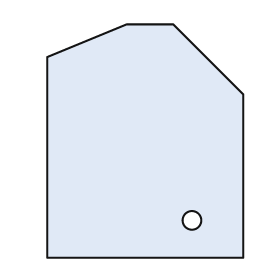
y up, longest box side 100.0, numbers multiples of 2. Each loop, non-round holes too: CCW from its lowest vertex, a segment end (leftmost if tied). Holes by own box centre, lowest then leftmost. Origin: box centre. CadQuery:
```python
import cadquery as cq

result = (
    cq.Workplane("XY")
    .moveTo(-42.0, -50.0)
    .lineTo(42.0, -50.0)
    .lineTo(42.0, 20.0)
    .lineTo(12.0, 50.0)
    .lineTo(-8.0, 50.0)
    .lineTo(-42.0, 36.0)
    .close()
    .moveTo(20.0, -34.0)
    .circle(4.0)
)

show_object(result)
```